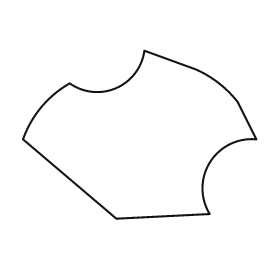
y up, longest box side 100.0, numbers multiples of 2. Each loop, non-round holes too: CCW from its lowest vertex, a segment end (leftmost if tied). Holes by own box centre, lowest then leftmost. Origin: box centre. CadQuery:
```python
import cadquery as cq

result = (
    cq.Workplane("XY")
    .moveTo(-10.0, -36.0)
    .lineTo(30.0, -34.0)
    .threePointArc((30.0, -12.0), (50.0, -2.0))
    .lineTo(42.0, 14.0)
    .threePointArc((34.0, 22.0), (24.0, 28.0))
    .lineTo(2.0, 36.0)
    .threePointArc((-10.0, 20.0), (-30.0, 22.0))
    .threePointArc((-42.0, 12.0), (-50.0, -2.0))
    .close()
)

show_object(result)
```